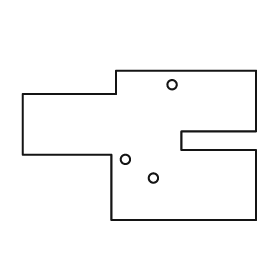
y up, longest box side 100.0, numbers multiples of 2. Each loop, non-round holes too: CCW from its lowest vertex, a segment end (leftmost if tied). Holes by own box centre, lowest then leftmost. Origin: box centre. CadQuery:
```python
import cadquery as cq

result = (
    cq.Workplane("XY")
    .moveTo(-12.0, -32.0)
    .lineTo(50.0, -32.0)
    .lineTo(50.0, -2.0)
    .lineTo(18.0, -2.0)
    .lineTo(18.0, 6.0)
    .lineTo(50.0, 6.0)
    .lineTo(50.0, 32.0)
    .lineTo(-10.0, 32.0)
    .lineTo(-10.0, 22.0)
    .lineTo(-50.0, 22.0)
    .lineTo(-50.0, -4.0)
    .lineTo(-12.0, -4.0)
    .close()
    .moveTo(6.0, -14.0)
    .circle(2.0)
    .moveTo(-6.0, -6.0)
    .circle(2.0)
    .moveTo(14.0, 26.0)
    .circle(2.0)
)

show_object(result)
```